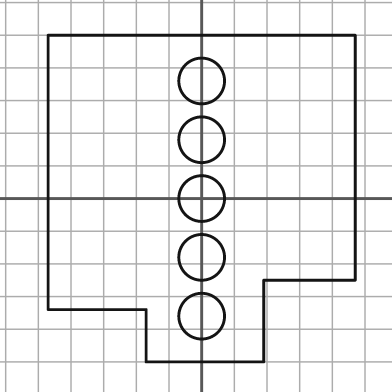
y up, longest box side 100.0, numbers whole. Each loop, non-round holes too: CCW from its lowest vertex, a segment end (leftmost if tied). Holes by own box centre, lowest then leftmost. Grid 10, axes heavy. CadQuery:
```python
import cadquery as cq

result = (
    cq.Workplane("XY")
    .moveTo(-17.0, -50.0)
    .lineTo(19.0, -50.0)
    .lineTo(19.0, -25.0)
    .lineTo(47.0, -25.0)
    .lineTo(47.0, 50.0)
    .lineTo(-47.0, 50.0)
    .lineTo(-47.0, -34.0)
    .lineTo(-17.0, -34.0)
    .close()
    .moveTo(0.0, -36.0)
    .circle(7.0)
    .moveTo(0.0, -18.0)
    .circle(7.0)
    .moveTo(0.0, 0.0)
    .circle(7.0)
    .moveTo(0.0, 18.0)
    .circle(7.0)
    .moveTo(0.0, 36.0)
    .circle(7.0)
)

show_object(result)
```